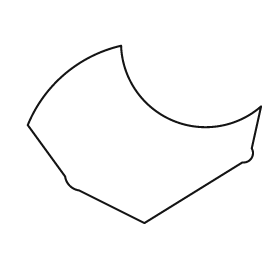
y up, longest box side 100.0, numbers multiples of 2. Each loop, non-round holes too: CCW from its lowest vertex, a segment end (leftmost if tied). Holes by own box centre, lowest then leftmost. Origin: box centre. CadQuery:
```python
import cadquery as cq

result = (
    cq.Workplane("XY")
    .moveTo(0.0, -38.0)
    .lineTo(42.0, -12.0)
    .threePointArc((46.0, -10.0), (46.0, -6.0))
    .lineTo(50.0, 12.0)
    .threePointArc((12.0, 6.0), (-10.0, 38.0))
    .threePointArc((-34.0, 26.0), (-50.0, 4.0))
    .lineTo(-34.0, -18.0)
    .threePointArc((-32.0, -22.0), (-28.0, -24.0))
    .close()
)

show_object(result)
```